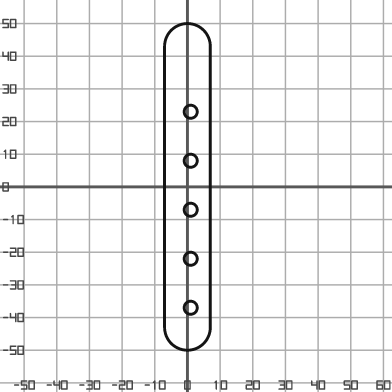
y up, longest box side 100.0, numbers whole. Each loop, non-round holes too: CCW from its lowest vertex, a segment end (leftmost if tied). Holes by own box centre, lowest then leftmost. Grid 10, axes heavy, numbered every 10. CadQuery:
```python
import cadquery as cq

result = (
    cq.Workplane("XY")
    .moveTo(-7.0, -43.0)
    .threePointArc((0.0, -50.0), (7.0, -43.0))
    .lineTo(7.0, 43.0)
    .threePointArc((0.0, 50.0), (-7.0, 43.0))
    .close()
    .moveTo(1.0, -37.0)
    .circle(2.0)
    .moveTo(1.0, -22.0)
    .circle(2.0)
    .moveTo(1.0, -7.0)
    .circle(2.0)
    .moveTo(1.0, 8.0)
    .circle(2.0)
    .moveTo(1.0, 23.0)
    .circle(2.0)
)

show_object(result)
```